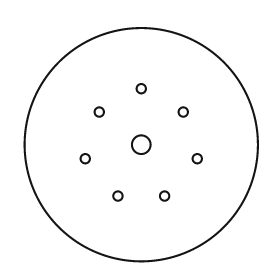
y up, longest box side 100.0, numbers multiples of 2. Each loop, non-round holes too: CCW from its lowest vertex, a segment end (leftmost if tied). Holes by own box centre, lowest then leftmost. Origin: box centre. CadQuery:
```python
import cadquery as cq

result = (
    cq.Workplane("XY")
    .moveTo(0.0, 0.0)
    .circle(50.0)
    .moveTo(-10.0, -22.0)
    .circle(2.0)
    .moveTo(10.0, -22.0)
    .circle(2.0)
    .moveTo(-24.0, -6.0)
    .circle(2.0)
    .moveTo(24.0, -6.0)
    .circle(2.0)
    .moveTo(0.0, 0.0)
    .circle(4.0)
    .moveTo(-18.0, 14.0)
    .circle(2.0)
    .moveTo(18.0, 14.0)
    .circle(2.0)
    .moveTo(0.0, 24.0)
    .circle(2.0)
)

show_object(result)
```